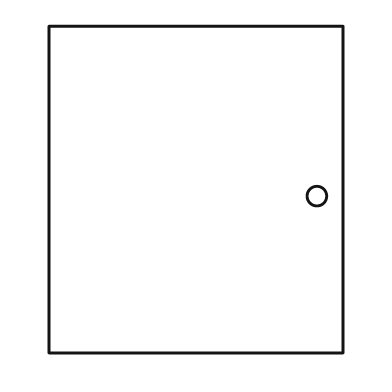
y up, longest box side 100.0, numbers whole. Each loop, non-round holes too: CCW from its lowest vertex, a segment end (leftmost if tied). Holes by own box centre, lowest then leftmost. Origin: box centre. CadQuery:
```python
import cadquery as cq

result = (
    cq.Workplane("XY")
    .moveTo(-45.0, -50.0)
    .lineTo(45.0, -50.0)
    .lineTo(45.0, 50.0)
    .lineTo(-45.0, 50.0)
    .close()
    .moveTo(37.0, -2.0)
    .circle(3.0)
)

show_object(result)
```